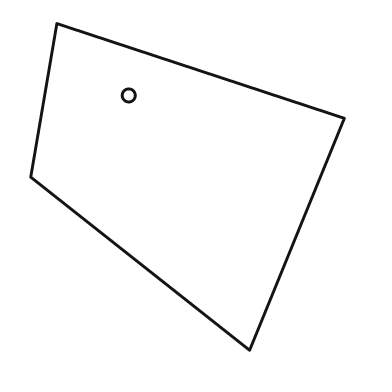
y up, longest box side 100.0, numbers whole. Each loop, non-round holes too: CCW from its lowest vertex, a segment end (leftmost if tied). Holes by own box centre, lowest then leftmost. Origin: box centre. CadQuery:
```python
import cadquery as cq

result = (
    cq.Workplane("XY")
    .moveTo(19.0, -50.0)
    .lineTo(48.0, 21.0)
    .lineTo(-40.0, 50.0)
    .lineTo(-48.0, 3.0)
    .close()
    .moveTo(-18.0, 28.0)
    .circle(2.0)
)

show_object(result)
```